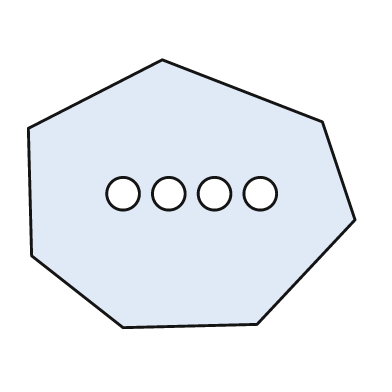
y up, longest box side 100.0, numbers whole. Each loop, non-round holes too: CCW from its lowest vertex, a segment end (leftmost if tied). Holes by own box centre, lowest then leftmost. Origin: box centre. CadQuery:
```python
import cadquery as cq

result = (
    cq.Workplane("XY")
    .moveTo(-21.0, -41.0)
    .lineTo(20.0, -40.0)
    .lineTo(50.0, -8.0)
    .lineTo(40.0, 22.0)
    .lineTo(-9.0, 41.0)
    .lineTo(-50.0, 20.0)
    .lineTo(-49.0, -19.0)
    .close()
    .moveTo(-21.0, 0.0)
    .circle(5.0)
    .moveTo(-7.0, 0.0)
    .circle(5.0)
    .moveTo(7.0, 0.0)
    .circle(5.0)
    .moveTo(21.0, 0.0)
    .circle(5.0)
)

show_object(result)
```